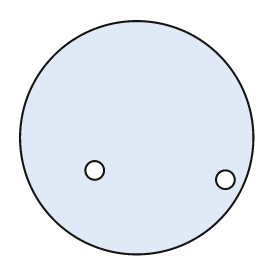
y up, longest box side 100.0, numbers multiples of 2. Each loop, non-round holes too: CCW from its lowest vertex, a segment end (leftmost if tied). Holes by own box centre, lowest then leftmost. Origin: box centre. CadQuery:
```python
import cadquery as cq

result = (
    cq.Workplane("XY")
    .moveTo(0.0, 0.0)
    .circle(50.0)
    .moveTo(38.0, -18.0)
    .circle(4.0)
    .moveTo(-18.0, -14.0)
    .circle(4.0)
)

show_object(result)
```